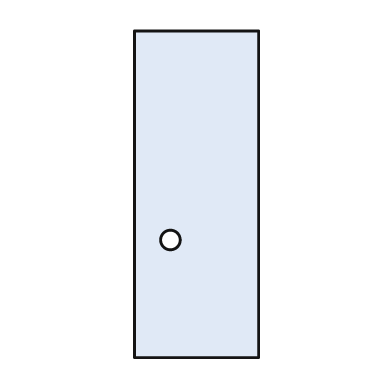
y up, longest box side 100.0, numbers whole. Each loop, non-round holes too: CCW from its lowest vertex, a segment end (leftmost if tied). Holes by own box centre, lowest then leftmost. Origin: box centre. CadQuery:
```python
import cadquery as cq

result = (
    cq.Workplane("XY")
    .moveTo(-19.0, -50.0)
    .lineTo(19.0, -50.0)
    .lineTo(19.0, 50.0)
    .lineTo(-19.0, 50.0)
    .close()
    .moveTo(-8.0, -14.0)
    .circle(3.0)
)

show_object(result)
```